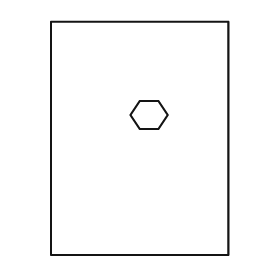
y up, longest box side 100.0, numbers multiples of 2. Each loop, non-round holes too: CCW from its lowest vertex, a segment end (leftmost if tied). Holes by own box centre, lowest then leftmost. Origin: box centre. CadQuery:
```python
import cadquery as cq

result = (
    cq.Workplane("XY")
    .moveTo(-38.0, -50.0)
    .lineTo(38.0, -50.0)
    .lineTo(38.0, 50.0)
    .lineTo(-38.0, 50.0)
    .close()
    .moveTo(0.0, 4.0)
    .lineTo(8.0, 4.0)
    .lineTo(12.0, 10.0)
    .lineTo(8.0, 16.0)
    .lineTo(0.0, 16.0)
    .lineTo(-4.0, 10.0)
    .close()
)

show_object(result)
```